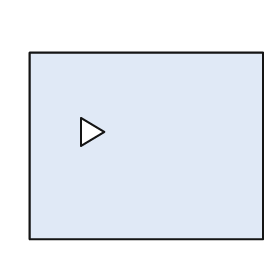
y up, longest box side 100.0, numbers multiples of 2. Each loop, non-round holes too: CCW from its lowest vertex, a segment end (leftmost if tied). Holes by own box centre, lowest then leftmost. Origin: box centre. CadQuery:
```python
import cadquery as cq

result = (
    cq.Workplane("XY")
    .moveTo(-50.0, -40.0)
    .lineTo(50.0, -40.0)
    .lineTo(50.0, 40.0)
    .lineTo(-50.0, 40.0)
    .close()
    .moveTo(-28.0, 0.0)
    .lineTo(-18.0, 6.0)
    .lineTo(-28.0, 12.0)
    .close()
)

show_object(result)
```